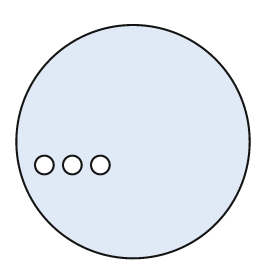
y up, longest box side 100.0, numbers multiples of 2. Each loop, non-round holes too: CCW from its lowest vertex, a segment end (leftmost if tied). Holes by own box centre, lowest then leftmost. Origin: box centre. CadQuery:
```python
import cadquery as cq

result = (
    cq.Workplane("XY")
    .moveTo(0.0, 0.0)
    .circle(50.0)
    .moveTo(-38.0, -10.0)
    .circle(4.0)
    .moveTo(-26.0, -10.0)
    .circle(4.0)
    .moveTo(-14.0, -10.0)
    .circle(4.0)
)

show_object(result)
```